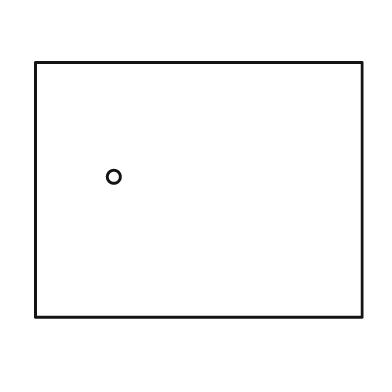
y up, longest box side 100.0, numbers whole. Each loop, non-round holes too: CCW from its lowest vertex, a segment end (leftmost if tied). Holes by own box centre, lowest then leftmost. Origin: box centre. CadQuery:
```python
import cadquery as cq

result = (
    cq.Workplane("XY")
    .moveTo(-50.0, -39.0)
    .lineTo(50.0, -39.0)
    .lineTo(50.0, 39.0)
    .lineTo(-50.0, 39.0)
    .close()
    .moveTo(-26.0, 4.0)
    .circle(2.0)
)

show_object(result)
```